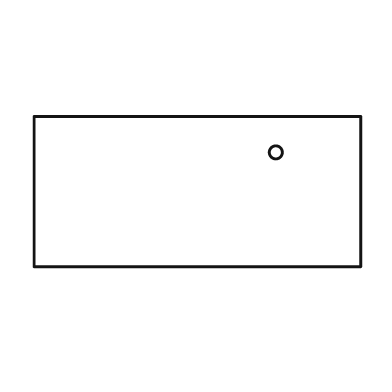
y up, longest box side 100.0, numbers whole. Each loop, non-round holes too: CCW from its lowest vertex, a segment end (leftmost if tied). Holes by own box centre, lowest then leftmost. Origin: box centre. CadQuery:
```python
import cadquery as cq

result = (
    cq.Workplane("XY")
    .moveTo(-50.0, -23.0)
    .lineTo(50.0, -23.0)
    .lineTo(50.0, 23.0)
    .lineTo(-50.0, 23.0)
    .close()
    .moveTo(24.0, 12.0)
    .circle(2.0)
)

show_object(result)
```